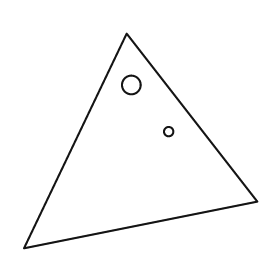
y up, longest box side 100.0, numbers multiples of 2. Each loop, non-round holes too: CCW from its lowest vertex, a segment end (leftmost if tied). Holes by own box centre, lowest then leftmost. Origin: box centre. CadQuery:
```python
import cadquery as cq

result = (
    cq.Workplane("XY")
    .moveTo(-50.0, -46.0)
    .lineTo(50.0, -26.0)
    .lineTo(-6.0, 46.0)
    .close()
    .moveTo(12.0, 4.0)
    .circle(2.0)
    .moveTo(-4.0, 24.0)
    .circle(4.0)
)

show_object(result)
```